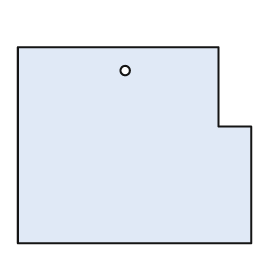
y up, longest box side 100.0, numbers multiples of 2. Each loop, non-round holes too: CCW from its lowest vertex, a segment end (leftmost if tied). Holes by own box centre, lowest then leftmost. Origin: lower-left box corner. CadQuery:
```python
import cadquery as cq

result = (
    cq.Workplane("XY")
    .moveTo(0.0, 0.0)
    .lineTo(100.0, 0.0)
    .lineTo(100.0, 50.0)
    .lineTo(86.0, 50.0)
    .lineTo(86.0, 84.0)
    .lineTo(0.0, 84.0)
    .close()
    .moveTo(46.0, 74.0)
    .circle(2.0)
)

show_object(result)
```